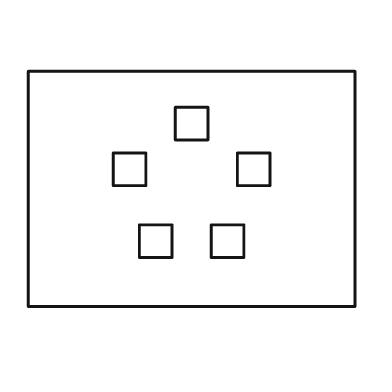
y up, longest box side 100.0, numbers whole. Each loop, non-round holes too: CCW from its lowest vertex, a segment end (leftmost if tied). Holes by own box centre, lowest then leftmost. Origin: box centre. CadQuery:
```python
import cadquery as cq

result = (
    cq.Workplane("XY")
    .moveTo(-50.0, -36.0)
    .lineTo(50.0, -36.0)
    .lineTo(50.0, 36.0)
    .lineTo(-50.0, 36.0)
    .close()
    .moveTo(-16.0, -21.0)
    .lineTo(-6.0, -21.0)
    .lineTo(-6.0, -11.0)
    .lineTo(-16.0, -11.0)
    .close()
    .moveTo(6.0, -21.0)
    .lineTo(16.0, -21.0)
    .lineTo(16.0, -11.0)
    .lineTo(6.0, -11.0)
    .close()
    .moveTo(-24.0, 1.0)
    .lineTo(-14.0, 1.0)
    .lineTo(-14.0, 11.0)
    .lineTo(-24.0, 11.0)
    .close()
    .moveTo(14.0, 1.0)
    .lineTo(24.0, 1.0)
    .lineTo(24.0, 11.0)
    .lineTo(14.0, 11.0)
    .close()
    .moveTo(-5.0, 15.0)
    .lineTo(5.0, 15.0)
    .lineTo(5.0, 25.0)
    .lineTo(-5.0, 25.0)
    .close()
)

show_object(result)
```